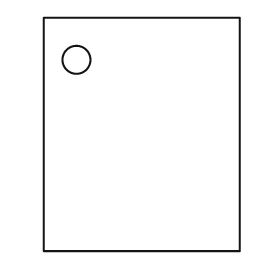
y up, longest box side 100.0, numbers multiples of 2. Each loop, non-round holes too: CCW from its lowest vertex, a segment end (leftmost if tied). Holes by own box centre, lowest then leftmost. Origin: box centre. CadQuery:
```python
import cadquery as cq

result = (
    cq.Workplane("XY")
    .moveTo(-42.0, -50.0)
    .lineTo(42.0, -50.0)
    .lineTo(42.0, 50.0)
    .lineTo(-42.0, 50.0)
    .close()
    .moveTo(-28.0, 32.0)
    .circle(6.0)
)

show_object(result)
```